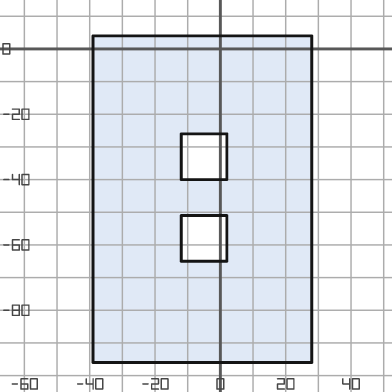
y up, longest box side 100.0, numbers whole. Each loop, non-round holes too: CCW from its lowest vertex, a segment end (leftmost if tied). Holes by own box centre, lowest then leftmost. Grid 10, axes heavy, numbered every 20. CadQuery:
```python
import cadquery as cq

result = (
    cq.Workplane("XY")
    .moveTo(-39.0, -96.0)
    .lineTo(28.0, -96.0)
    .lineTo(28.0, 4.0)
    .lineTo(-39.0, 4.0)
    .close()
    .moveTo(-12.0, -65.0)
    .lineTo(2.0, -65.0)
    .lineTo(2.0, -51.0)
    .lineTo(-12.0, -51.0)
    .close()
    .moveTo(-12.0, -40.0)
    .lineTo(2.0, -40.0)
    .lineTo(2.0, -26.0)
    .lineTo(-12.0, -26.0)
    .close()
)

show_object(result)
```